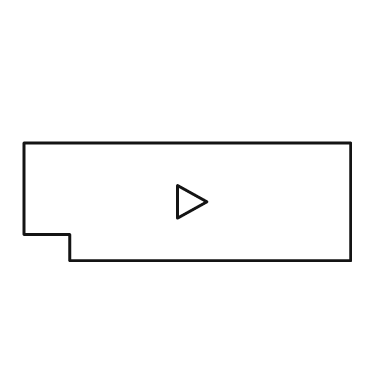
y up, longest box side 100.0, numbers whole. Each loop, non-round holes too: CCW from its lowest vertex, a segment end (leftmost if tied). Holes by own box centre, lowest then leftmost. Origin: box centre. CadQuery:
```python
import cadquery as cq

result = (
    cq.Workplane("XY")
    .moveTo(-36.0, -18.0)
    .lineTo(50.0, -18.0)
    .lineTo(50.0, 18.0)
    .lineTo(-50.0, 18.0)
    .lineTo(-50.0, -10.0)
    .lineTo(-36.0, -10.0)
    .close()
    .moveTo(-3.0, -5.0)
    .lineTo(6.0, 0.0)
    .lineTo(-3.0, 5.0)
    .close()
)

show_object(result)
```